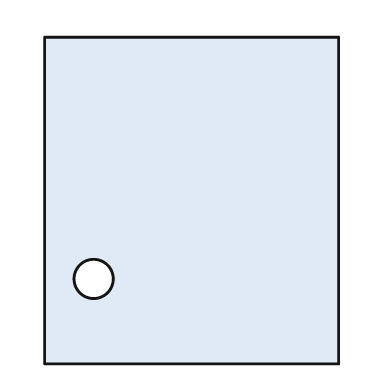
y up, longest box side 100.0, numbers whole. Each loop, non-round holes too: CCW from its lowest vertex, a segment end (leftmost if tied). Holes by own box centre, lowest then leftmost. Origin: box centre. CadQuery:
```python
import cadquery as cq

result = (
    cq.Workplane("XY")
    .moveTo(-45.0, -50.0)
    .lineTo(45.0, -50.0)
    .lineTo(45.0, 50.0)
    .lineTo(-45.0, 50.0)
    .close()
    .moveTo(-30.0, -24.0)
    .circle(6.0)
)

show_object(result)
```